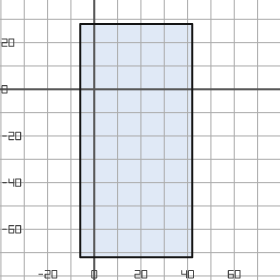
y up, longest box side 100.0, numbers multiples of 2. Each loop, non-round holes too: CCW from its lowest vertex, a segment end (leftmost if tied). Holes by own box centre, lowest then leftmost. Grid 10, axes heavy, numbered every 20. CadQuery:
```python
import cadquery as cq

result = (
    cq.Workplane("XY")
    .moveTo(-6.0, -72.0)
    .lineTo(42.0, -72.0)
    .lineTo(42.0, 28.0)
    .lineTo(-6.0, 28.0)
    .close()
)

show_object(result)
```